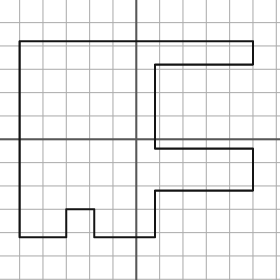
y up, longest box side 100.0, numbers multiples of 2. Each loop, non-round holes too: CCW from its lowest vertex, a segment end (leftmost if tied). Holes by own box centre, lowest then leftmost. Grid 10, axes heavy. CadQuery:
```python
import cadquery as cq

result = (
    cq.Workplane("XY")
    .moveTo(-50.0, -42.0)
    .lineTo(-30.0, -42.0)
    .lineTo(-30.0, -30.0)
    .lineTo(-18.0, -30.0)
    .lineTo(-18.0, -42.0)
    .lineTo(8.0, -42.0)
    .lineTo(8.0, -22.0)
    .lineTo(50.0, -22.0)
    .lineTo(50.0, -4.0)
    .lineTo(8.0, -4.0)
    .lineTo(8.0, 32.0)
    .lineTo(50.0, 32.0)
    .lineTo(50.0, 42.0)
    .lineTo(-50.0, 42.0)
    .close()
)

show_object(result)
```